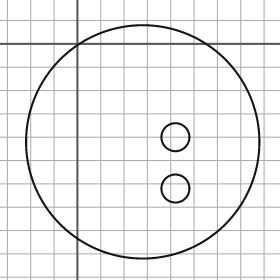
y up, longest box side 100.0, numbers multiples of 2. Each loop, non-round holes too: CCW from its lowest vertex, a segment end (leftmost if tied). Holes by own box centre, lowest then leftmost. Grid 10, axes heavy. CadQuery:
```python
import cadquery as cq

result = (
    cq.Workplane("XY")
    .moveTo(28.0, -42.0)
    .circle(50.0)
    .moveTo(42.0, -62.0)
    .circle(6.0)
    .moveTo(42.0, -40.0)
    .circle(6.0)
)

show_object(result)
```